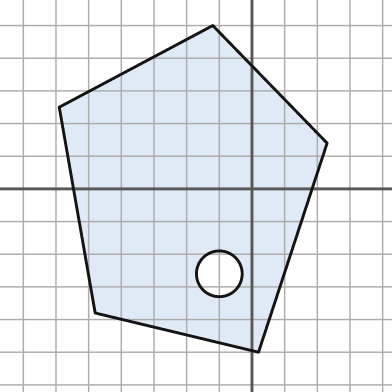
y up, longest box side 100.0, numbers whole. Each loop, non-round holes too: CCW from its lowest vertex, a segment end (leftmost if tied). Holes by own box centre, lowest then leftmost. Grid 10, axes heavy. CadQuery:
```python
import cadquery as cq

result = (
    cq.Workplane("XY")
    .moveTo(2.0, -50.0)
    .lineTo(23.0, 14.0)
    .lineTo(-12.0, 50.0)
    .lineTo(-59.0, 25.0)
    .lineTo(-48.0, -38.0)
    .close()
    .moveTo(-10.0, -26.0)
    .circle(7.0)
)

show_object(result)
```